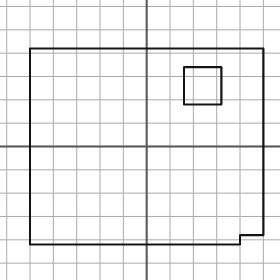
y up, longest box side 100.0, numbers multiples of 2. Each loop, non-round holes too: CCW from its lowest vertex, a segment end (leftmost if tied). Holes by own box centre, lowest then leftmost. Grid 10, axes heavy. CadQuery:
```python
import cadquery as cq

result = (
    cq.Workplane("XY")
    .moveTo(-50.0, -42.0)
    .lineTo(40.0, -42.0)
    .lineTo(40.0, -38.0)
    .lineTo(50.0, -38.0)
    .lineTo(50.0, 42.0)
    .lineTo(-50.0, 42.0)
    .close()
    .moveTo(16.0, 18.0)
    .lineTo(32.0, 18.0)
    .lineTo(32.0, 34.0)
    .lineTo(16.0, 34.0)
    .close()
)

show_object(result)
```